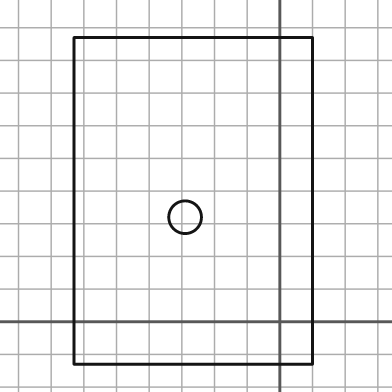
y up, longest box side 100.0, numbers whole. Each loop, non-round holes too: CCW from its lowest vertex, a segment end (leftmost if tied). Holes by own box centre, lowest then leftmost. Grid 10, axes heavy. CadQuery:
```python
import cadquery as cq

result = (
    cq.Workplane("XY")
    .moveTo(-63.0, -13.0)
    .lineTo(10.0, -13.0)
    .lineTo(10.0, 87.0)
    .lineTo(-63.0, 87.0)
    .close()
    .moveTo(-29.0, 32.0)
    .circle(5.0)
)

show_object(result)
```